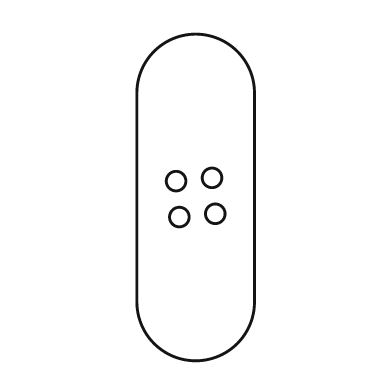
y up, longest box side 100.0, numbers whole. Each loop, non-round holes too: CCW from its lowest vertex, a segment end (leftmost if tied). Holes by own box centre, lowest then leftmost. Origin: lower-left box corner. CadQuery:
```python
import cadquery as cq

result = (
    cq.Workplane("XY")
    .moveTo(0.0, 18.0)
    .threePointArc((18.0, 0.0), (36.0, 18.0))
    .lineTo(36.0, 82.0)
    .threePointArc((18.0, 100.0), (0.0, 82.0))
    .close()
    .moveTo(13.0, 44.0)
    .circle(3.0)
    .moveTo(24.0, 45.0)
    .circle(3.0)
    .moveTo(12.0, 55.0)
    .circle(3.0)
    .moveTo(23.0, 56.0)
    .circle(3.0)
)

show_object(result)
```